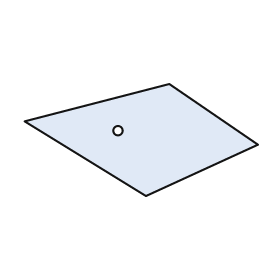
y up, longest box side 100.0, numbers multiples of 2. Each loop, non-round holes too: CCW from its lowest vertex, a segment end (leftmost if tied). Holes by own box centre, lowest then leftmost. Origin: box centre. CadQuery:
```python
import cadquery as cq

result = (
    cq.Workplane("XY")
    .moveTo(2.0, -24.0)
    .lineTo(50.0, -2.0)
    .lineTo(12.0, 24.0)
    .lineTo(-50.0, 8.0)
    .close()
    .moveTo(-10.0, 4.0)
    .circle(2.0)
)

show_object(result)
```